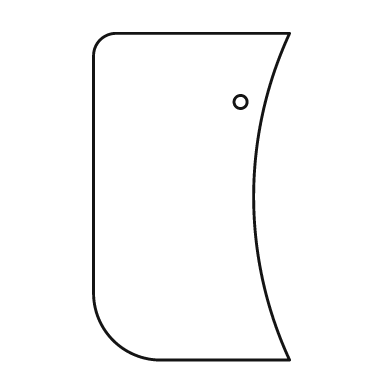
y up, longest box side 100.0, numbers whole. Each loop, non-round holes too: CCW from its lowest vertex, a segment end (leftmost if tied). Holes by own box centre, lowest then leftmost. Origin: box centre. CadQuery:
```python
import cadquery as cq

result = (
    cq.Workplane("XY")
    .moveTo(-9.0, -50.0)
    .lineTo(30.0, -50.0)
    .threePointArc((19.0, 0.0), (30.0, 50.0))
    .lineTo(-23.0, 50.0)
    .threePointArc((-28.0, 48.0), (-30.0, 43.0))
    .lineTo(-30.0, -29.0)
    .threePointArc((-24.0, -44.0), (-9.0, -50.0))
    .close()
    .moveTo(15.0, 29.0)
    .circle(2.0)
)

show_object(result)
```